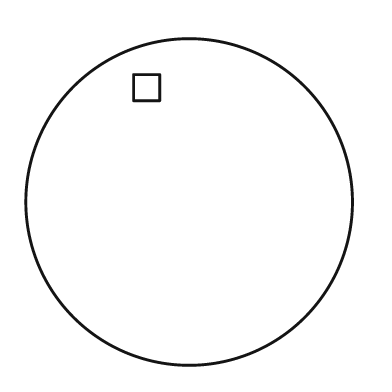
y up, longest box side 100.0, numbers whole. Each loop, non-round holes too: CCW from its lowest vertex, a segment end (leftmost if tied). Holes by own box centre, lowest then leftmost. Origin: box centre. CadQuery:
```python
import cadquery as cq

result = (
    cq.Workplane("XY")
    .moveTo(0.0, 0.0)
    .circle(50.0)
    .moveTo(-17.0, 31.0)
    .lineTo(-9.0, 31.0)
    .lineTo(-9.0, 39.0)
    .lineTo(-17.0, 39.0)
    .close()
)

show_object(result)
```